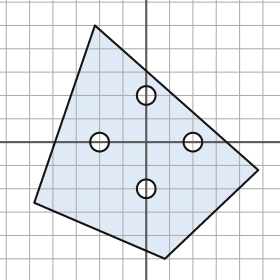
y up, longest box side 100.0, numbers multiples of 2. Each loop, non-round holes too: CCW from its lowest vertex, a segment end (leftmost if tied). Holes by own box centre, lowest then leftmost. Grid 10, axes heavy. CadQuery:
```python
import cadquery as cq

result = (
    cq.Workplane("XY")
    .moveTo(8.0, -50.0)
    .lineTo(48.0, -12.0)
    .lineTo(-22.0, 50.0)
    .lineTo(-48.0, -26.0)
    .close()
    .moveTo(0.0, -20.0)
    .circle(4.0)
    .moveTo(-20.0, 0.0)
    .circle(4.0)
    .moveTo(20.0, 0.0)
    .circle(4.0)
    .moveTo(0.0, 20.0)
    .circle(4.0)
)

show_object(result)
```